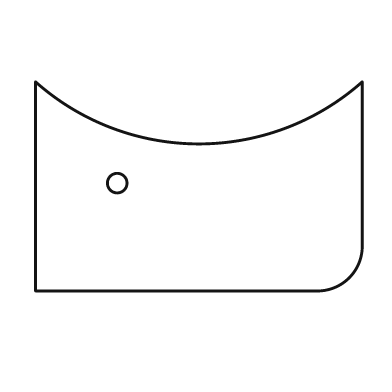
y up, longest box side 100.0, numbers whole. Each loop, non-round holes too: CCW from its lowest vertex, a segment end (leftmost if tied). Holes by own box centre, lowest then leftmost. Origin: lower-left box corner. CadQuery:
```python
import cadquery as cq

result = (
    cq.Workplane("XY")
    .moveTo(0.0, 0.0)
    .lineTo(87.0, 0.0)
    .threePointArc((96.0, 4.0), (100.0, 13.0))
    .lineTo(100.0, 64.0)
    .threePointArc((50.0, 45.0), (0.0, 64.0))
    .close()
    .moveTo(25.0, 33.0)
    .circle(3.0)
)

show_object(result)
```